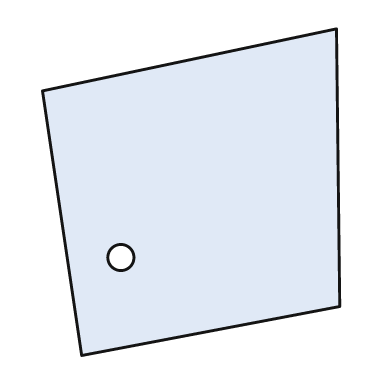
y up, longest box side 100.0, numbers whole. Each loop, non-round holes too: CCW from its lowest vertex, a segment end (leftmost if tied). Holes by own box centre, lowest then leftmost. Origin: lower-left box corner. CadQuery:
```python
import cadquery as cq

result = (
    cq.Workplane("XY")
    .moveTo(12.0, 0.0)
    .lineTo(91.0, 15.0)
    .lineTo(90.0, 100.0)
    .lineTo(0.0, 81.0)
    .close()
    .moveTo(24.0, 30.0)
    .circle(4.0)
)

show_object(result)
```